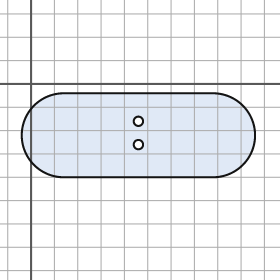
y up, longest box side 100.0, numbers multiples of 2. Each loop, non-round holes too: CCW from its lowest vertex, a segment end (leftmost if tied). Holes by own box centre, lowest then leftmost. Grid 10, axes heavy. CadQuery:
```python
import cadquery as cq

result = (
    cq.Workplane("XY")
    .moveTo(14.0, -40.0)
    .lineTo(78.0, -40.0)
    .threePointArc((96.0, -22.0), (78.0, -4.0))
    .lineTo(14.0, -4.0)
    .threePointArc((-4.0, -22.0), (14.0, -40.0))
    .close()
    .moveTo(46.0, -26.0)
    .circle(2.0)
    .moveTo(46.0, -16.0)
    .circle(2.0)
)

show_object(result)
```